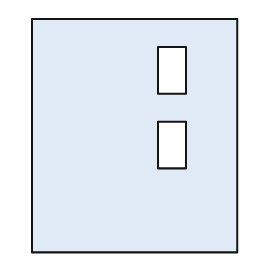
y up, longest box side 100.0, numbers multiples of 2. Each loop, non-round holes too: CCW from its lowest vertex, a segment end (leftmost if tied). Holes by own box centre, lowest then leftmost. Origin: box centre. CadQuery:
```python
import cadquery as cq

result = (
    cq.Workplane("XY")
    .moveTo(-44.0, -50.0)
    .lineTo(44.0, -50.0)
    .lineTo(44.0, 50.0)
    .lineTo(-44.0, 50.0)
    .close()
    .moveTo(10.0, -14.0)
    .lineTo(22.0, -14.0)
    .lineTo(22.0, 6.0)
    .lineTo(10.0, 6.0)
    .close()
    .moveTo(10.0, 18.0)
    .lineTo(22.0, 18.0)
    .lineTo(22.0, 38.0)
    .lineTo(10.0, 38.0)
    .close()
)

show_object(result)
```